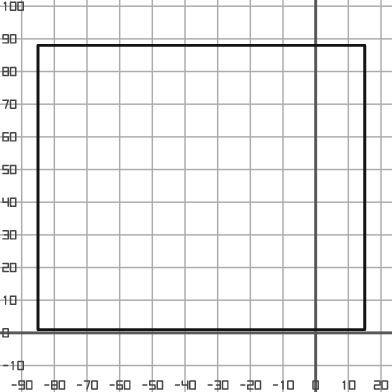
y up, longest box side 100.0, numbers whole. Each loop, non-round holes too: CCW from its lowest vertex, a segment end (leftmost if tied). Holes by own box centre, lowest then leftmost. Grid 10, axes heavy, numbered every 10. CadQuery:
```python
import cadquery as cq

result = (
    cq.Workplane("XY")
    .moveTo(-85.0, 1.0)
    .lineTo(15.0, 1.0)
    .lineTo(15.0, 88.0)
    .lineTo(-85.0, 88.0)
    .close()
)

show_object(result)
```